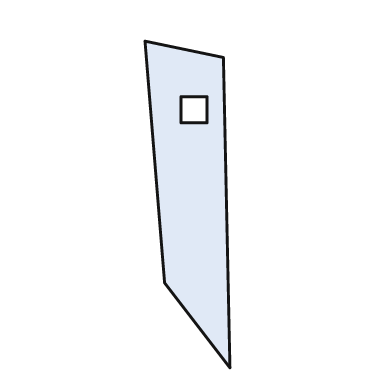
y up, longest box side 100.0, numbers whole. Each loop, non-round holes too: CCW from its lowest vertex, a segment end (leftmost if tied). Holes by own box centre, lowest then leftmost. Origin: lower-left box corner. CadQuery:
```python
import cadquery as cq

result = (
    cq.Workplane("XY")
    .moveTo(26.0, 0.0)
    .lineTo(24.0, 95.0)
    .lineTo(0.0, 100.0)
    .lineTo(6.0, 26.0)
    .close()
    .moveTo(11.0, 75.0)
    .lineTo(19.0, 75.0)
    .lineTo(19.0, 83.0)
    .lineTo(11.0, 83.0)
    .close()
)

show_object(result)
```